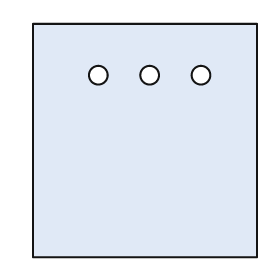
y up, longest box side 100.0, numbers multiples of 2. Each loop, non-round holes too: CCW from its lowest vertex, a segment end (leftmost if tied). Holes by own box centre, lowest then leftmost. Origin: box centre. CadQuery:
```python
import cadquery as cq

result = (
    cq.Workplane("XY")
    .moveTo(-48.0, -50.0)
    .lineTo(48.0, -50.0)
    .lineTo(48.0, 50.0)
    .lineTo(-48.0, 50.0)
    .close()
    .moveTo(-20.0, 28.0)
    .circle(4.0)
    .moveTo(2.0, 28.0)
    .circle(4.0)
    .moveTo(24.0, 28.0)
    .circle(4.0)
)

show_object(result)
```